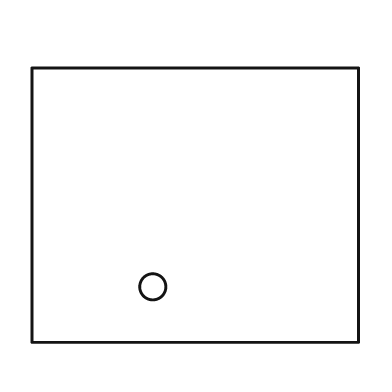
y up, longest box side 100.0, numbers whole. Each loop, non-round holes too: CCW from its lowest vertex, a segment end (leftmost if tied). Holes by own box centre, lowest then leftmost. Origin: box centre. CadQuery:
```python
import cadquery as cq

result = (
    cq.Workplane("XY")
    .moveTo(-50.0, -42.0)
    .lineTo(50.0, -42.0)
    .lineTo(50.0, 42.0)
    .lineTo(-50.0, 42.0)
    .close()
    .moveTo(-13.0, -25.0)
    .circle(4.0)
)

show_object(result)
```